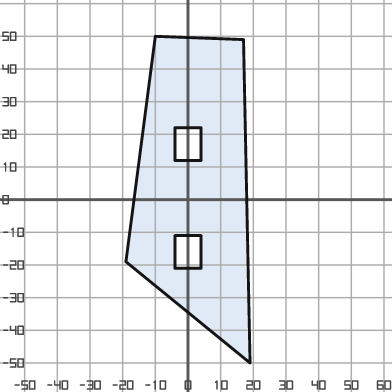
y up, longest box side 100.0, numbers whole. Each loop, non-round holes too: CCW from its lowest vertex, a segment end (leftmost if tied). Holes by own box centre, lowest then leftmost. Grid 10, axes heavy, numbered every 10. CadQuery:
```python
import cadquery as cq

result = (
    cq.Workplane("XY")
    .moveTo(19.0, -50.0)
    .lineTo(17.0, 49.0)
    .lineTo(-10.0, 50.0)
    .lineTo(-19.0, -19.0)
    .close()
    .moveTo(-4.0, -21.0)
    .lineTo(4.0, -21.0)
    .lineTo(4.0, -11.0)
    .lineTo(-4.0, -11.0)
    .close()
    .moveTo(-4.0, 12.0)
    .lineTo(4.0, 12.0)
    .lineTo(4.0, 22.0)
    .lineTo(-4.0, 22.0)
    .close()
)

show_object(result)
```